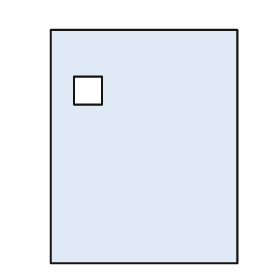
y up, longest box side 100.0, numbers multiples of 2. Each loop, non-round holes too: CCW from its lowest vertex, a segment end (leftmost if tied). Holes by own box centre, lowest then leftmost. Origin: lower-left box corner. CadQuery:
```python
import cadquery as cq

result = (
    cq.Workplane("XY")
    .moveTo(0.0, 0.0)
    .lineTo(80.0, 0.0)
    .lineTo(80.0, 100.0)
    .lineTo(0.0, 100.0)
    .close()
    .moveTo(10.0, 68.0)
    .lineTo(22.0, 68.0)
    .lineTo(22.0, 80.0)
    .lineTo(10.0, 80.0)
    .close()
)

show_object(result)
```